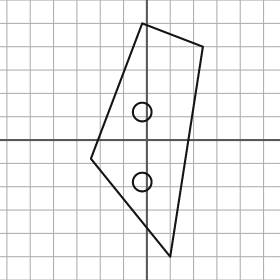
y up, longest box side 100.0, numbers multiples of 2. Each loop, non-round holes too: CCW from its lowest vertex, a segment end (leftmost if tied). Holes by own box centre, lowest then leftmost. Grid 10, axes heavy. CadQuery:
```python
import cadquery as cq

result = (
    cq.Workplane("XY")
    .moveTo(10.0, -50.0)
    .lineTo(24.0, 40.0)
    .lineTo(-2.0, 50.0)
    .lineTo(-24.0, -8.0)
    .close()
    .moveTo(-2.0, -18.0)
    .circle(4.0)
    .moveTo(-2.0, 12.0)
    .circle(4.0)
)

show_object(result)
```